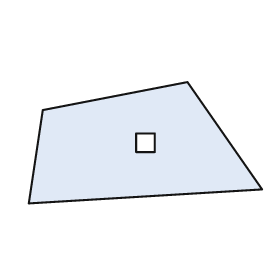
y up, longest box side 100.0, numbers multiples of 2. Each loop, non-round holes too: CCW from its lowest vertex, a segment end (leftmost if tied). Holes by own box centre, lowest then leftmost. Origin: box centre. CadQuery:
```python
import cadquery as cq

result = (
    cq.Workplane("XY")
    .moveTo(-50.0, -26.0)
    .lineTo(50.0, -20.0)
    .lineTo(18.0, 26.0)
    .lineTo(-44.0, 14.0)
    .close()
    .moveTo(-4.0, -4.0)
    .lineTo(4.0, -4.0)
    .lineTo(4.0, 4.0)
    .lineTo(-4.0, 4.0)
    .close()
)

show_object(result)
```